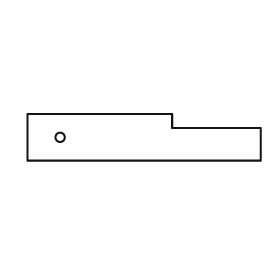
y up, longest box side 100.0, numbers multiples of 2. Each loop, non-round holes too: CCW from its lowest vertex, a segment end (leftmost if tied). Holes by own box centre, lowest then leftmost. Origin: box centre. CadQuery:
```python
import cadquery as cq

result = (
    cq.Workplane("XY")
    .moveTo(-50.0, -10.0)
    .lineTo(50.0, -10.0)
    .lineTo(50.0, 4.0)
    .lineTo(12.0, 4.0)
    .lineTo(12.0, 10.0)
    .lineTo(-50.0, 10.0)
    .close()
    .moveTo(-36.0, 0.0)
    .circle(2.0)
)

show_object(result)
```